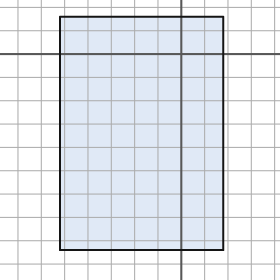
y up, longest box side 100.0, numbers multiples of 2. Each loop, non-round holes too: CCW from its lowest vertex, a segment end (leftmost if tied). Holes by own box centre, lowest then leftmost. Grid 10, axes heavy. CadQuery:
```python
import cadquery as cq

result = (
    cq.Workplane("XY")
    .moveTo(-52.0, -84.0)
    .lineTo(18.0, -84.0)
    .lineTo(18.0, 16.0)
    .lineTo(-52.0, 16.0)
    .close()
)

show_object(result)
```